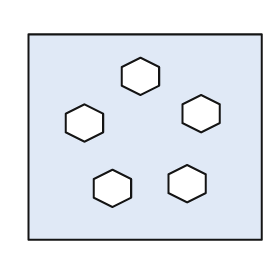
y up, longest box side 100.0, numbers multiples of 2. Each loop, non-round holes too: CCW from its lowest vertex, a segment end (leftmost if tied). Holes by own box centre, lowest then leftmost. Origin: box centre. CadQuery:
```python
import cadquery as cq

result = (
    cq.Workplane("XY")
    .moveTo(-50.0, -44.0)
    .lineTo(50.0, -44.0)
    .lineTo(50.0, 44.0)
    .lineTo(-50.0, 44.0)
    .close()
    .moveTo(-14.0, -30.0)
    .lineTo(-6.0, -26.0)
    .lineTo(-6.0, -18.0)
    .lineTo(-14.0, -14.0)
    .lineTo(-22.0, -18.0)
    .lineTo(-22.0, -26.0)
    .close()
    .moveTo(18.0, -28.0)
    .lineTo(26.0, -24.0)
    .lineTo(26.0, -16.0)
    .lineTo(18.0, -12.0)
    .lineTo(10.0, -16.0)
    .lineTo(10.0, -24.0)
    .close()
    .moveTo(-26.0, -2.0)
    .lineTo(-18.0, 2.0)
    .lineTo(-18.0, 10.0)
    .lineTo(-26.0, 14.0)
    .lineTo(-34.0, 10.0)
    .lineTo(-34.0, 2.0)
    .close()
    .moveTo(24.0, 2.0)
    .lineTo(32.0, 6.0)
    .lineTo(32.0, 14.0)
    .lineTo(24.0, 18.0)
    .lineTo(16.0, 14.0)
    .lineTo(16.0, 6.0)
    .close()
    .moveTo(-2.0, 18.0)
    .lineTo(6.0, 22.0)
    .lineTo(6.0, 30.0)
    .lineTo(-2.0, 34.0)
    .lineTo(-10.0, 30.0)
    .lineTo(-10.0, 22.0)
    .close()
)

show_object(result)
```